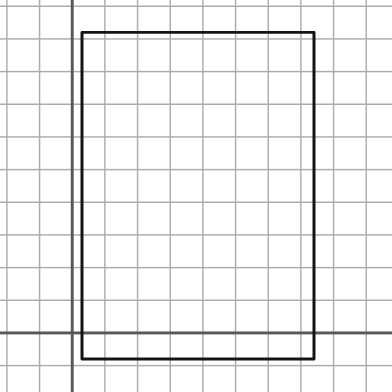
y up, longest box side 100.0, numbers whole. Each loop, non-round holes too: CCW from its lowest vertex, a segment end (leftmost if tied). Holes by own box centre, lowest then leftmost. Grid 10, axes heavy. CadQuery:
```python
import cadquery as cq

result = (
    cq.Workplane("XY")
    .moveTo(3.0, -8.0)
    .lineTo(74.0, -8.0)
    .lineTo(74.0, 92.0)
    .lineTo(3.0, 92.0)
    .close()
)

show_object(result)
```